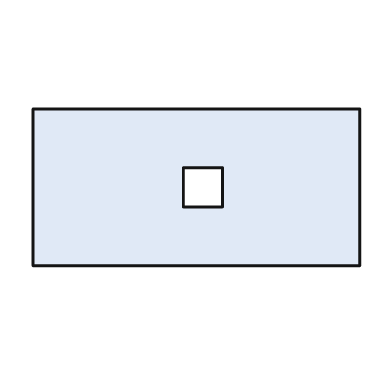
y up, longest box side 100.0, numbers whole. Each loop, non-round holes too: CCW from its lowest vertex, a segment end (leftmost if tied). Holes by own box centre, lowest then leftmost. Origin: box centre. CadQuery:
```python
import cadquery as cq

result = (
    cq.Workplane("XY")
    .moveTo(-50.0, -24.0)
    .lineTo(50.0, -24.0)
    .lineTo(50.0, 24.0)
    .lineTo(-50.0, 24.0)
    .close()
    .moveTo(-4.0, -6.0)
    .lineTo(8.0, -6.0)
    .lineTo(8.0, 6.0)
    .lineTo(-4.0, 6.0)
    .close()
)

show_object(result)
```